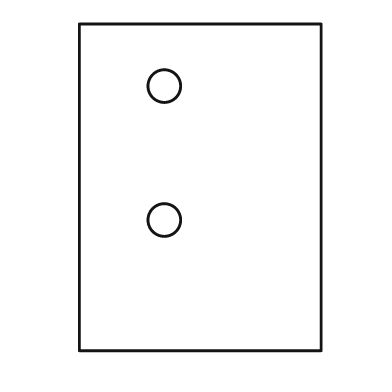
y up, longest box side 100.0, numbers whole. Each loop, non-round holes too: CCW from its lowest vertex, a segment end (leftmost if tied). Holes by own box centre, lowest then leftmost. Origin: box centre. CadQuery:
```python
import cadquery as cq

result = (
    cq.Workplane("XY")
    .moveTo(-37.0, -50.0)
    .lineTo(37.0, -50.0)
    .lineTo(37.0, 50.0)
    .lineTo(-37.0, 50.0)
    .close()
    .moveTo(-11.0, -10.0)
    .circle(5.0)
    .moveTo(-11.0, 31.0)
    .circle(5.0)
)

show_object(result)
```